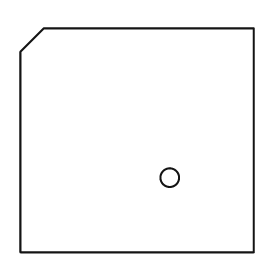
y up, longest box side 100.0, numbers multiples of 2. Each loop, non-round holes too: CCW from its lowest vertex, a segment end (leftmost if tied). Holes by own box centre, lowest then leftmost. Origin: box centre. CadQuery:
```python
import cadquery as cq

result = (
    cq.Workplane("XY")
    .moveTo(-50.0, -48.0)
    .lineTo(50.0, -48.0)
    .lineTo(50.0, 48.0)
    .lineTo(-40.0, 48.0)
    .lineTo(-50.0, 38.0)
    .close()
    .moveTo(14.0, -16.0)
    .circle(4.0)
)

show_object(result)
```